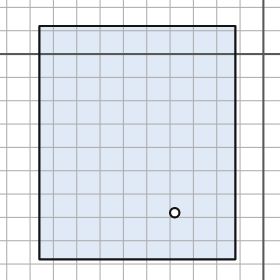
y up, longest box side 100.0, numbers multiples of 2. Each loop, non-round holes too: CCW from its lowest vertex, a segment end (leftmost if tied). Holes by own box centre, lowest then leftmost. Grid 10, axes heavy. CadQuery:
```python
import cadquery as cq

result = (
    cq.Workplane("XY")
    .moveTo(-96.0, -88.0)
    .lineTo(-12.0, -88.0)
    .lineTo(-12.0, 12.0)
    .lineTo(-96.0, 12.0)
    .close()
    .moveTo(-38.0, -68.0)
    .circle(2.0)
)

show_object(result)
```